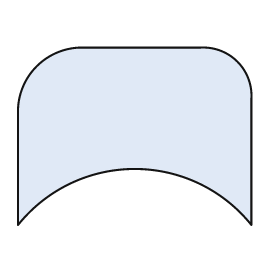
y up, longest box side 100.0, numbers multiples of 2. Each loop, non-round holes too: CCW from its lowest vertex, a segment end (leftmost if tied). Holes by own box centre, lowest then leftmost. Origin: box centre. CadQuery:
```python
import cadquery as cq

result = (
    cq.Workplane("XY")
    .moveTo(-50.0, -38.0)
    .threePointArc((0.0, -14.0), (50.0, -38.0))
    .lineTo(50.0, 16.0)
    .threePointArc((44.0, 32.0), (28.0, 38.0))
    .lineTo(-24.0, 38.0)
    .threePointArc((-42.0, 30.0), (-50.0, 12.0))
    .close()
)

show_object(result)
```